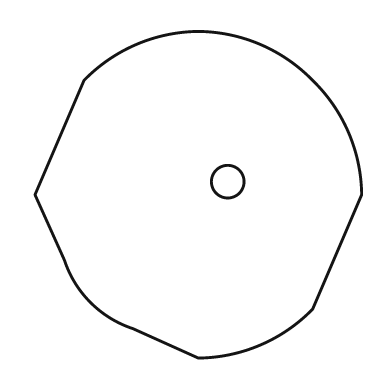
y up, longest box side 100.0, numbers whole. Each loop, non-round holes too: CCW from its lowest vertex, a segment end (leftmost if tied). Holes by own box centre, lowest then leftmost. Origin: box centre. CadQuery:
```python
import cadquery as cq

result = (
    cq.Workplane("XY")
    .moveTo(0.0, -50.0)
    .threePointArc((19.0, -46.0), (35.0, -35.0))
    .lineTo(50.0, 0.0)
    .threePointArc((46.0, 19.0), (35.0, 35.0))
    .threePointArc((19.0, 46.0), (0.0, 50.0))
    .threePointArc((-19.0, 46.0), (-35.0, 35.0))
    .lineTo(-50.0, 0.0)
    .lineTo(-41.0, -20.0)
    .threePointArc((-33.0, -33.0), (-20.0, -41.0))
    .close()
    .moveTo(9.0, 4.0)
    .circle(5.0)
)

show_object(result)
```